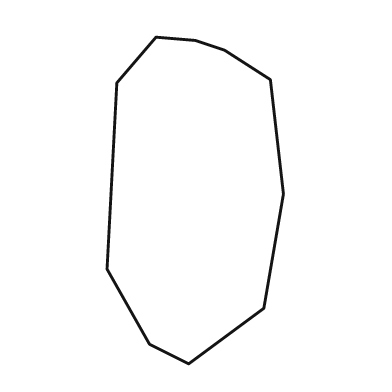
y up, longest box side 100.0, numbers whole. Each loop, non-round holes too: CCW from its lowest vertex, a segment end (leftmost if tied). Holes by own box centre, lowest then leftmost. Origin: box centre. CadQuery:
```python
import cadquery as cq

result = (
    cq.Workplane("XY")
    .moveTo(-2.0, -50.0)
    .lineTo(21.0, -33.0)
    .lineTo(27.0, 2.0)
    .lineTo(23.0, 37.0)
    .lineTo(9.0, 46.0)
    .lineTo(0.0, 49.0)
    .lineTo(-12.0, 50.0)
    .lineTo(-24.0, 36.0)
    .lineTo(-27.0, -21.0)
    .lineTo(-14.0, -44.0)
    .close()
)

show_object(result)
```